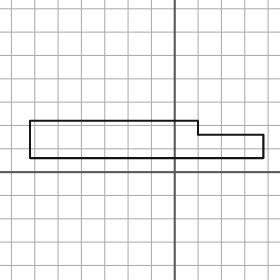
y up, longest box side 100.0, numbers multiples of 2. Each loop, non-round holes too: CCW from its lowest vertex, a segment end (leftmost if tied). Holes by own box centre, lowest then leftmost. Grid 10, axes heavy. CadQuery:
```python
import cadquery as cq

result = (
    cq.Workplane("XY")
    .moveTo(-62.0, 6.0)
    .lineTo(38.0, 6.0)
    .lineTo(38.0, 16.0)
    .lineTo(10.0, 16.0)
    .lineTo(10.0, 22.0)
    .lineTo(-62.0, 22.0)
    .close()
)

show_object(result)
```